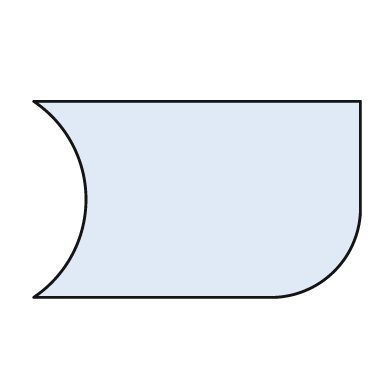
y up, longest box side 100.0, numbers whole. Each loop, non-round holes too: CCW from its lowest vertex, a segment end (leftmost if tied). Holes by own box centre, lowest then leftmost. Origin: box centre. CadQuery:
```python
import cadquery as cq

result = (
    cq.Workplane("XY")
    .moveTo(-50.0, -30.0)
    .lineTo(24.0, -30.0)
    .threePointArc((42.0, -22.0), (50.0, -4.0))
    .lineTo(50.0, 30.0)
    .lineTo(-50.0, 30.0)
    .threePointArc((-34.0, 0.0), (-50.0, -30.0))
    .close()
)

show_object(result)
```